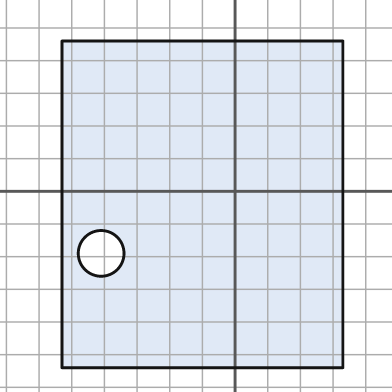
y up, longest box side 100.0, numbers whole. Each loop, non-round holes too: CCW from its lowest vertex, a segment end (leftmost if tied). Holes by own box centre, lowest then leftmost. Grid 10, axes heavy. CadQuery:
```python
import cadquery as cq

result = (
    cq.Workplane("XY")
    .moveTo(-53.0, -54.0)
    .lineTo(33.0, -54.0)
    .lineTo(33.0, 46.0)
    .lineTo(-53.0, 46.0)
    .close()
    .moveTo(-41.0, -19.0)
    .circle(7.0)
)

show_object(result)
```